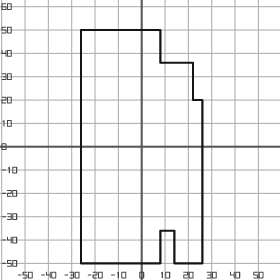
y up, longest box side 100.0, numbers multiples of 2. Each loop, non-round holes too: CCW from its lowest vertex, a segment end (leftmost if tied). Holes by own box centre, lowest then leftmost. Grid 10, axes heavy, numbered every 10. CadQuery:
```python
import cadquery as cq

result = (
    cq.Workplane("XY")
    .moveTo(-26.0, -50.0)
    .lineTo(8.0, -50.0)
    .lineTo(8.0, -36.0)
    .lineTo(14.0, -36.0)
    .lineTo(14.0, -50.0)
    .lineTo(26.0, -50.0)
    .lineTo(26.0, 20.0)
    .lineTo(22.0, 20.0)
    .lineTo(22.0, 36.0)
    .lineTo(8.0, 36.0)
    .lineTo(8.0, 50.0)
    .lineTo(-26.0, 50.0)
    .close()
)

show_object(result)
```